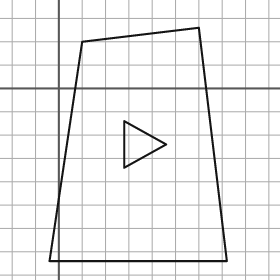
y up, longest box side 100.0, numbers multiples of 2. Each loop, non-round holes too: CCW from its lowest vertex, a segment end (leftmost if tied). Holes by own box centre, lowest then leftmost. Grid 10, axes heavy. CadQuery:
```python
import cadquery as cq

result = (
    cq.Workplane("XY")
    .moveTo(-4.0, -74.0)
    .lineTo(72.0, -74.0)
    .lineTo(60.0, 26.0)
    .lineTo(10.0, 20.0)
    .close()
    .moveTo(28.0, -34.0)
    .lineTo(46.0, -24.0)
    .lineTo(28.0, -14.0)
    .close()
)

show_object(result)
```